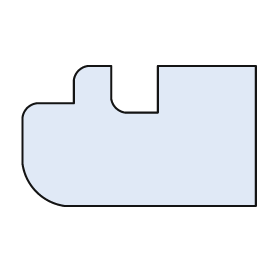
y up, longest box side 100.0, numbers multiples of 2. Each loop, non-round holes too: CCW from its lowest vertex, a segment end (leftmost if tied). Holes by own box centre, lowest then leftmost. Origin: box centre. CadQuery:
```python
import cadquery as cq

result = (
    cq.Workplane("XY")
    .moveTo(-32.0, -30.0)
    .lineTo(50.0, -30.0)
    .lineTo(50.0, 30.0)
    .lineTo(8.0, 30.0)
    .lineTo(8.0, 10.0)
    .lineTo(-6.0, 10.0)
    .threePointArc((-10.0, 12.0), (-12.0, 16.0))
    .lineTo(-12.0, 30.0)
    .lineTo(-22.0, 30.0)
    .threePointArc((-26.0, 28.0), (-28.0, 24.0))
    .lineTo(-28.0, 14.0)
    .lineTo(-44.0, 14.0)
    .threePointArc((-48.0, 12.0), (-50.0, 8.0))
    .lineTo(-50.0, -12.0)
    .threePointArc((-44.0, -24.0), (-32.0, -30.0))
    .close()
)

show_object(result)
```